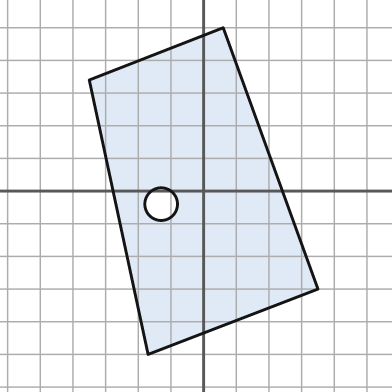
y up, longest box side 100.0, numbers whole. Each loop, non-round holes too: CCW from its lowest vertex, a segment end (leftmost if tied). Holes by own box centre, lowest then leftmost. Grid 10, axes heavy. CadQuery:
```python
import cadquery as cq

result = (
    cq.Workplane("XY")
    .moveTo(-17.0, -50.0)
    .lineTo(35.0, -30.0)
    .lineTo(6.0, 50.0)
    .lineTo(-35.0, 34.0)
    .close()
    .moveTo(-13.0, -4.0)
    .circle(5.0)
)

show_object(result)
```